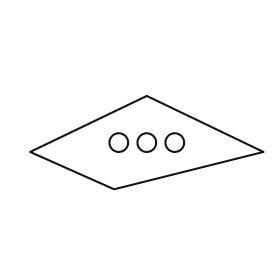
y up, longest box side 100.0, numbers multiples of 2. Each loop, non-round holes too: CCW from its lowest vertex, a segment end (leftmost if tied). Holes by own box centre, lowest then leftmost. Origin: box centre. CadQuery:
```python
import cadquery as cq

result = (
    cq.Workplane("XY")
    .moveTo(-14.0, -20.0)
    .lineTo(50.0, -4.0)
    .lineTo(0.0, 20.0)
    .lineTo(-50.0, -4.0)
    .close()
    .moveTo(-12.0, 0.0)
    .circle(4.0)
    .moveTo(0.0, 0.0)
    .circle(4.0)
    .moveTo(12.0, 0.0)
    .circle(4.0)
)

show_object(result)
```